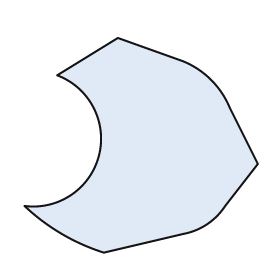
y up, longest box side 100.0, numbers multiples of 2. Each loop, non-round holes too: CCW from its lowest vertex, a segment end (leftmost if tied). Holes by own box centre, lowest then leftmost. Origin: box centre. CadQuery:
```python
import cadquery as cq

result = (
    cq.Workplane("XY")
    .moveTo(-16.0, -46.0)
    .lineTo(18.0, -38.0)
    .threePointArc((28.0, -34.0), (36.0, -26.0))
    .lineTo(50.0, -8.0)
    .lineTo(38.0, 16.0)
    .threePointArc((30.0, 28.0), (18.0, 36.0))
    .lineTo(-10.0, 46.0)
    .lineTo(-36.0, 30.0)
    .threePointArc((-18.0, -4.0), (-50.0, -26.0))
    .threePointArc((-34.0, -38.0), (-16.0, -46.0))
    .close()
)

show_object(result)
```